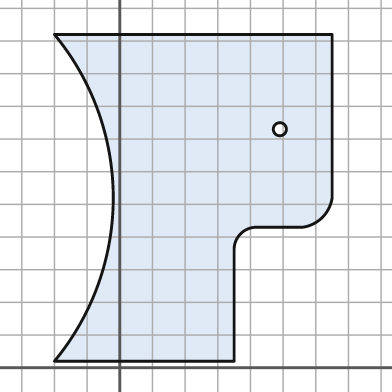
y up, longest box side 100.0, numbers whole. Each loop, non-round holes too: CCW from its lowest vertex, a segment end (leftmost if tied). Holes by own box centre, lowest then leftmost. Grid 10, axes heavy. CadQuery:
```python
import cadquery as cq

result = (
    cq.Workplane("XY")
    .moveTo(-20.0, 2.0)
    .lineTo(35.0, 2.0)
    .lineTo(35.0, 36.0)
    .threePointArc((37.0, 41.0), (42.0, 43.0))
    .lineTo(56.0, 43.0)
    .threePointArc((62.0, 46.0), (65.0, 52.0))
    .lineTo(65.0, 102.0)
    .lineTo(-20.0, 102.0)
    .threePointArc((-2.0, 52.0), (-20.0, 2.0))
    .close()
    .moveTo(49.0, 73.0)
    .circle(2.0)
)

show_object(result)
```